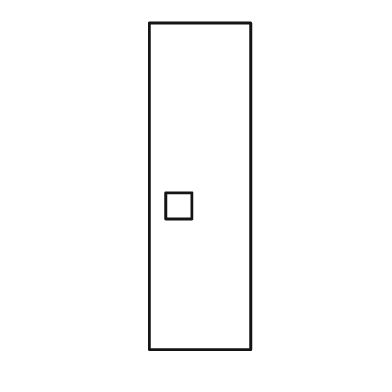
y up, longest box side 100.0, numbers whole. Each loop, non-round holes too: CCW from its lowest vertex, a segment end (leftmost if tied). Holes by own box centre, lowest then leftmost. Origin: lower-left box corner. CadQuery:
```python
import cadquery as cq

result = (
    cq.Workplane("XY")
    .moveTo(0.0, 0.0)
    .lineTo(31.0, 0.0)
    .lineTo(31.0, 100.0)
    .lineTo(0.0, 100.0)
    .close()
    .moveTo(5.0, 40.0)
    .lineTo(13.0, 40.0)
    .lineTo(13.0, 48.0)
    .lineTo(5.0, 48.0)
    .close()
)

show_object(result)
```